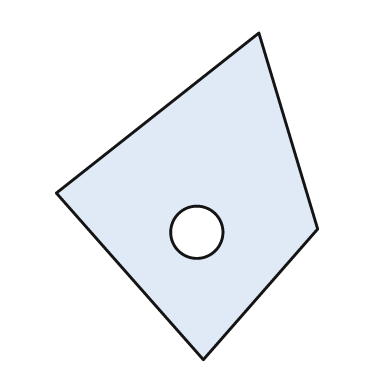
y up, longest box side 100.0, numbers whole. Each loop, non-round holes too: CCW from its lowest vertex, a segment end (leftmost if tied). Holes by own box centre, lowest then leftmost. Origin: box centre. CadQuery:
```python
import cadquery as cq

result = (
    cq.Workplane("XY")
    .moveTo(5.0, -50.0)
    .lineTo(40.0, -10.0)
    .lineTo(22.0, 50.0)
    .lineTo(-40.0, 1.0)
    .close()
    .moveTo(3.0, -11.0)
    .circle(8.0)
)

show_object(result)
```